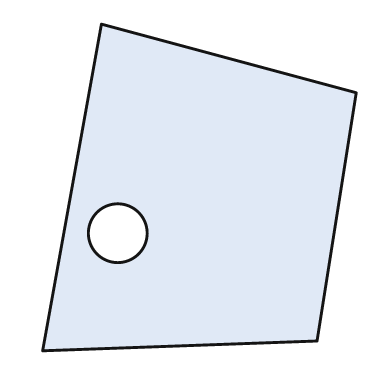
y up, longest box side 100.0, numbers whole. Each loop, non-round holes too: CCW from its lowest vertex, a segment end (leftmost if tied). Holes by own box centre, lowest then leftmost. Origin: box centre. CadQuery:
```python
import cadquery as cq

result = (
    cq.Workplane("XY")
    .moveTo(-48.0, -50.0)
    .lineTo(36.0, -47.0)
    .lineTo(48.0, 29.0)
    .lineTo(-30.0, 50.0)
    .close()
    .moveTo(-25.0, -14.0)
    .circle(9.0)
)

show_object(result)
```